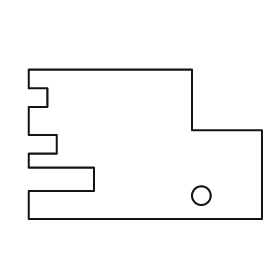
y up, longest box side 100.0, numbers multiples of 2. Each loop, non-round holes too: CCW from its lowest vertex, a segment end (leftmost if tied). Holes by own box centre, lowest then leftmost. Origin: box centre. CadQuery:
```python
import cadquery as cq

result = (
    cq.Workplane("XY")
    .moveTo(-50.0, -32.0)
    .lineTo(50.0, -32.0)
    .lineTo(50.0, 6.0)
    .lineTo(20.0, 6.0)
    .lineTo(20.0, 32.0)
    .lineTo(-50.0, 32.0)
    .lineTo(-50.0, 24.0)
    .lineTo(-42.0, 24.0)
    .lineTo(-42.0, 16.0)
    .lineTo(-50.0, 16.0)
    .lineTo(-50.0, 4.0)
    .lineTo(-38.0, 4.0)
    .lineTo(-38.0, -4.0)
    .lineTo(-50.0, -4.0)
    .lineTo(-50.0, -10.0)
    .lineTo(-22.0, -10.0)
    .lineTo(-22.0, -20.0)
    .lineTo(-50.0, -20.0)
    .close()
    .moveTo(24.0, -22.0)
    .circle(4.0)
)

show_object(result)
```